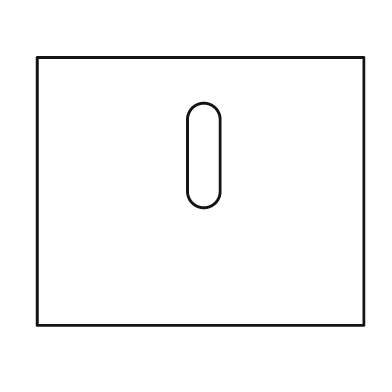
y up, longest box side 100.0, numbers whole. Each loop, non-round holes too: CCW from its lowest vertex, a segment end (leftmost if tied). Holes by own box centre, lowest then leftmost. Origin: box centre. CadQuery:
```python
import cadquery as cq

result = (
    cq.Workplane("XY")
    .moveTo(-50.0, -41.0)
    .lineTo(50.0, -41.0)
    .lineTo(50.0, 41.0)
    .lineTo(-50.0, 41.0)
    .close()
    .moveTo(-4.0, 0.0)
    .threePointArc((1.0, -5.0), (6.0, 0.0))
    .lineTo(6.0, 22.0)
    .threePointArc((1.0, 27.0), (-4.0, 22.0))
    .close()
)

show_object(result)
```